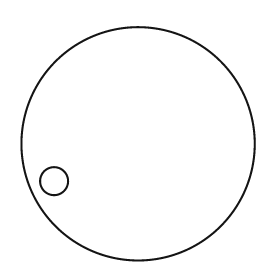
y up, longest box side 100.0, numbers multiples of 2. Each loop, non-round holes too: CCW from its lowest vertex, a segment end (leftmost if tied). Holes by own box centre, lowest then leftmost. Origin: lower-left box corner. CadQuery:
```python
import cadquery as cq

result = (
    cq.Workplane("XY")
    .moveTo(50.0, 50.0)
    .circle(50.0)
    .moveTo(14.0, 34.0)
    .circle(6.0)
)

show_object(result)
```